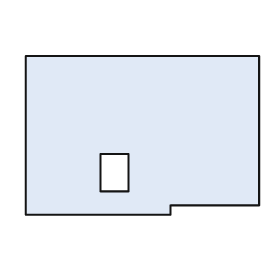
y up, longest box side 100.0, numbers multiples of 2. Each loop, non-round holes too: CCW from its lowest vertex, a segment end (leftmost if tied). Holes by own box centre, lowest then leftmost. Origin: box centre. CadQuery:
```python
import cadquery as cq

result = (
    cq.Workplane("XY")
    .moveTo(-50.0, -34.0)
    .lineTo(12.0, -34.0)
    .lineTo(12.0, -30.0)
    .lineTo(50.0, -30.0)
    .lineTo(50.0, 34.0)
    .lineTo(-50.0, 34.0)
    .close()
    .moveTo(-18.0, -24.0)
    .lineTo(-6.0, -24.0)
    .lineTo(-6.0, -8.0)
    .lineTo(-18.0, -8.0)
    .close()
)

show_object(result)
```